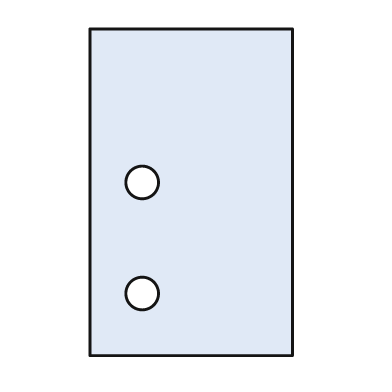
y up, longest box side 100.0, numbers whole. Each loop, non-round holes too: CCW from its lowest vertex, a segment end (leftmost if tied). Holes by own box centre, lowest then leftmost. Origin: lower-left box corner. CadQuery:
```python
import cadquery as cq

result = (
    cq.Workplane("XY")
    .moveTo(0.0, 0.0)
    .lineTo(62.0, 0.0)
    .lineTo(62.0, 100.0)
    .lineTo(0.0, 100.0)
    .close()
    .moveTo(16.0, 19.0)
    .circle(5.0)
    .moveTo(16.0, 53.0)
    .circle(5.0)
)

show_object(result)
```